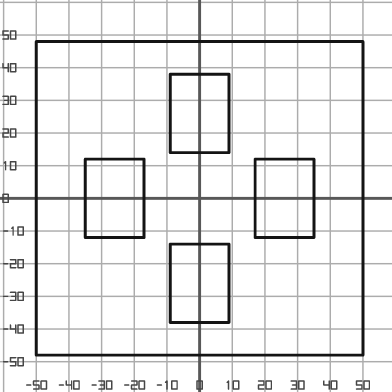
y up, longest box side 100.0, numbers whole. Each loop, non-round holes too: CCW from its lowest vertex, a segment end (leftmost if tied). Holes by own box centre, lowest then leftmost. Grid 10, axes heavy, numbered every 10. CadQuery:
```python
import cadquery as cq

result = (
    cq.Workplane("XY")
    .moveTo(-50.0, -48.0)
    .lineTo(50.0, -48.0)
    .lineTo(50.0, 48.0)
    .lineTo(-50.0, 48.0)
    .close()
    .moveTo(-9.0, -38.0)
    .lineTo(9.0, -38.0)
    .lineTo(9.0, -14.0)
    .lineTo(-9.0, -14.0)
    .close()
    .moveTo(-35.0, -12.0)
    .lineTo(-17.0, -12.0)
    .lineTo(-17.0, 12.0)
    .lineTo(-35.0, 12.0)
    .close()
    .moveTo(17.0, -12.0)
    .lineTo(35.0, -12.0)
    .lineTo(35.0, 12.0)
    .lineTo(17.0, 12.0)
    .close()
    .moveTo(-9.0, 14.0)
    .lineTo(9.0, 14.0)
    .lineTo(9.0, 38.0)
    .lineTo(-9.0, 38.0)
    .close()
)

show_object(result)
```